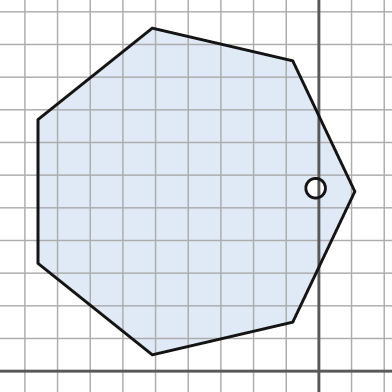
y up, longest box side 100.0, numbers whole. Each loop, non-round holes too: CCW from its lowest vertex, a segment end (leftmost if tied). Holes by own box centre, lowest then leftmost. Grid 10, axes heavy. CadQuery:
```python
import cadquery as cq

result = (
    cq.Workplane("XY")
    .moveTo(-51.0, 5.0)
    .lineTo(-8.0, 15.0)
    .lineTo(11.0, 55.0)
    .lineTo(-8.0, 95.0)
    .lineTo(-51.0, 105.0)
    .lineTo(-86.0, 77.0)
    .lineTo(-86.0, 33.0)
    .close()
    .moveTo(-1.0, 56.0)
    .circle(3.0)
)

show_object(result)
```